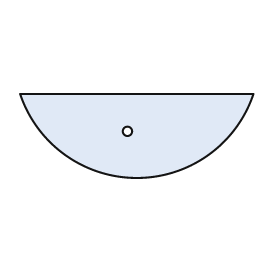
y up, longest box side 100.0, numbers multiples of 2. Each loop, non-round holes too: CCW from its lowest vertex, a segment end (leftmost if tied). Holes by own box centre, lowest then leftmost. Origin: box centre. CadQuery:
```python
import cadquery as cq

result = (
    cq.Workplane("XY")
    .moveTo(-50.0, 18.0)
    .threePointArc((0.0, -18.0), (50.0, 18.0))
    .close()
    .moveTo(-4.0, 2.0)
    .circle(2.0)
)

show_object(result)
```